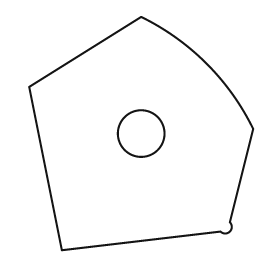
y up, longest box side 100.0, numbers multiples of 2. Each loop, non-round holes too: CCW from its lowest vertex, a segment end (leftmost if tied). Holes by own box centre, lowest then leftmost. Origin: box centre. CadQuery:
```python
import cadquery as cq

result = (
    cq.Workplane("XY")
    .moveTo(-34.0, -50.0)
    .lineTo(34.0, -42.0)
    .threePointArc((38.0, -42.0), (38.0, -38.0))
    .lineTo(48.0, 2.0)
    .threePointArc((28.0, 30.0), (0.0, 50.0))
    .lineTo(-48.0, 20.0)
    .close()
    .moveTo(0.0, 0.0)
    .circle(10.0)
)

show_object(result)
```